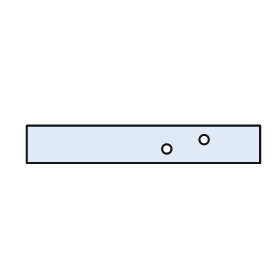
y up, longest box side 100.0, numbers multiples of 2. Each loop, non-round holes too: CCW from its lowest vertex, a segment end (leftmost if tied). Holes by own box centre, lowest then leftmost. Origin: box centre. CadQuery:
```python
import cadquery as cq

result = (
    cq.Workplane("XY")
    .moveTo(-50.0, -8.0)
    .lineTo(50.0, -8.0)
    .lineTo(50.0, 8.0)
    .lineTo(-50.0, 8.0)
    .close()
    .moveTo(10.0, -2.0)
    .circle(2.0)
    .moveTo(26.0, 2.0)
    .circle(2.0)
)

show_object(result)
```